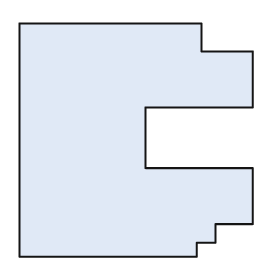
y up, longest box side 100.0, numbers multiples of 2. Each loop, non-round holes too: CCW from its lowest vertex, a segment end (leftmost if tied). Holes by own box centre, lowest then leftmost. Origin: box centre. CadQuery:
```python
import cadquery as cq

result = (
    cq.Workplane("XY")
    .moveTo(-50.0, -50.0)
    .lineTo(26.0, -50.0)
    .lineTo(26.0, -44.0)
    .lineTo(34.0, -44.0)
    .lineTo(34.0, -36.0)
    .lineTo(50.0, -36.0)
    .lineTo(50.0, -12.0)
    .lineTo(4.0, -12.0)
    .lineTo(4.0, 14.0)
    .lineTo(50.0, 14.0)
    .lineTo(50.0, 38.0)
    .lineTo(28.0, 38.0)
    .lineTo(28.0, 50.0)
    .lineTo(-50.0, 50.0)
    .close()
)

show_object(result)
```